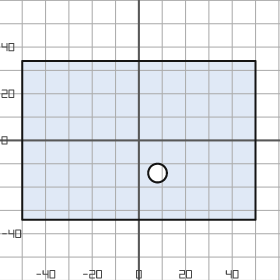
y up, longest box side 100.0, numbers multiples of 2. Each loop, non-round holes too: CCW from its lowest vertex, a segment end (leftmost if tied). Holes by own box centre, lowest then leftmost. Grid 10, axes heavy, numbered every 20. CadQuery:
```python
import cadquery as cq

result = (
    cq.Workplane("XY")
    .moveTo(-50.0, -34.0)
    .lineTo(50.0, -34.0)
    .lineTo(50.0, 34.0)
    .lineTo(-50.0, 34.0)
    .close()
    .moveTo(8.0, -14.0)
    .circle(4.0)
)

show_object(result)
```